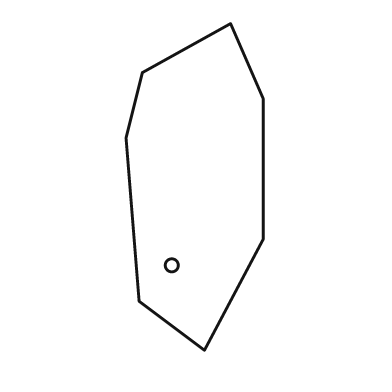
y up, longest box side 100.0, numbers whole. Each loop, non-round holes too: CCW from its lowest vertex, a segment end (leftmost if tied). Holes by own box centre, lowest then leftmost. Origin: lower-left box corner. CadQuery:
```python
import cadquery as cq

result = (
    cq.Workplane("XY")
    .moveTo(24.0, 0.0)
    .lineTo(42.0, 34.0)
    .lineTo(42.0, 77.0)
    .lineTo(32.0, 100.0)
    .lineTo(5.0, 85.0)
    .lineTo(0.0, 65.0)
    .lineTo(4.0, 15.0)
    .close()
    .moveTo(14.0, 26.0)
    .circle(2.0)
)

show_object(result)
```